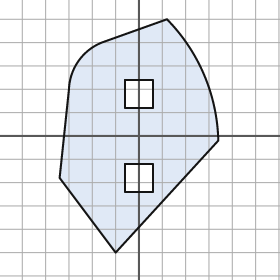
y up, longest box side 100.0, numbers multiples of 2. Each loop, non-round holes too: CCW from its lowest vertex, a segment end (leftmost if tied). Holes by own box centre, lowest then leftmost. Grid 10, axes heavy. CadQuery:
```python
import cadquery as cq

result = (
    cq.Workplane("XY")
    .moveTo(-10.0, -50.0)
    .lineTo(34.0, -2.0)
    .threePointArc((28.0, 26.0), (12.0, 50.0))
    .lineTo(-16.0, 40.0)
    .threePointArc((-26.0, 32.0), (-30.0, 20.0))
    .lineTo(-34.0, -18.0)
    .close()
    .moveTo(-6.0, -24.0)
    .lineTo(6.0, -24.0)
    .lineTo(6.0, -12.0)
    .lineTo(-6.0, -12.0)
    .close()
    .moveTo(-6.0, 12.0)
    .lineTo(6.0, 12.0)
    .lineTo(6.0, 24.0)
    .lineTo(-6.0, 24.0)
    .close()
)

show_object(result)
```